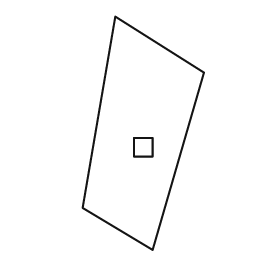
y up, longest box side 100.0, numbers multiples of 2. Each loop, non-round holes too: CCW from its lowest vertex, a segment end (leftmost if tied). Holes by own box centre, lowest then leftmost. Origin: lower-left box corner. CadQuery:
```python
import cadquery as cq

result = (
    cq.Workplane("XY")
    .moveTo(30.0, 0.0)
    .lineTo(52.0, 76.0)
    .lineTo(14.0, 100.0)
    .lineTo(0.0, 18.0)
    .close()
    .moveTo(22.0, 40.0)
    .lineTo(30.0, 40.0)
    .lineTo(30.0, 48.0)
    .lineTo(22.0, 48.0)
    .close()
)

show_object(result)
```